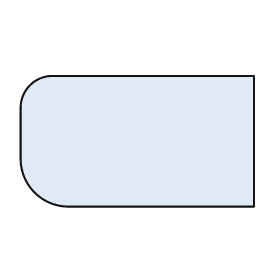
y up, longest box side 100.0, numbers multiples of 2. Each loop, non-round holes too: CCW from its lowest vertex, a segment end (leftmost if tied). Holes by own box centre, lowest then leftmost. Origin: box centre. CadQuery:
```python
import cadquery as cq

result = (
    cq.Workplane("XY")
    .moveTo(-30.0, -28.0)
    .lineTo(50.0, -28.0)
    .lineTo(50.0, 28.0)
    .lineTo(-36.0, 28.0)
    .threePointArc((-46.0, 24.0), (-50.0, 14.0))
    .lineTo(-50.0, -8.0)
    .threePointArc((-44.0, -22.0), (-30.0, -28.0))
    .close()
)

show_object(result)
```